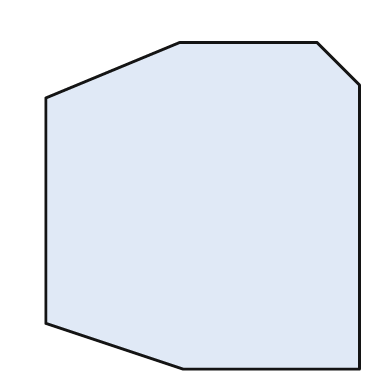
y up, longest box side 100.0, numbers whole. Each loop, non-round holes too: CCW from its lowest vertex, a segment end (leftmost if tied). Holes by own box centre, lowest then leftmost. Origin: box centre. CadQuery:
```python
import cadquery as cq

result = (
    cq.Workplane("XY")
    .moveTo(-6.0, -50.0)
    .lineTo(48.0, -50.0)
    .lineTo(48.0, 37.0)
    .lineTo(35.0, 50.0)
    .lineTo(-7.0, 50.0)
    .lineTo(-48.0, 33.0)
    .lineTo(-48.0, -36.0)
    .close()
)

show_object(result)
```